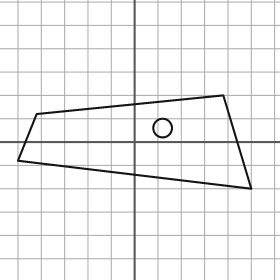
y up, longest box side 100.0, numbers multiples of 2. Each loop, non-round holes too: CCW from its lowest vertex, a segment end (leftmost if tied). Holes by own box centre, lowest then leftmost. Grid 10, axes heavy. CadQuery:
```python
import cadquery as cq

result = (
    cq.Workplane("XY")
    .moveTo(50.0, -20.0)
    .lineTo(38.0, 20.0)
    .lineTo(-42.0, 12.0)
    .lineTo(-50.0, -8.0)
    .close()
    .moveTo(12.0, 6.0)
    .circle(4.0)
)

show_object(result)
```